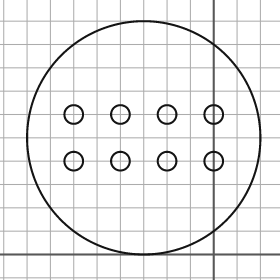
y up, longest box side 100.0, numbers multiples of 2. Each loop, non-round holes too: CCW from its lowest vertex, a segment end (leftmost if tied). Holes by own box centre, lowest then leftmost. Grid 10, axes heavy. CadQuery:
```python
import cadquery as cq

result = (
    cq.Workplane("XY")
    .moveTo(-30.0, 50.0)
    .circle(50.0)
    .moveTo(-60.0, 40.0)
    .circle(4.0)
    .moveTo(-40.0, 40.0)
    .circle(4.0)
    .moveTo(-20.0, 40.0)
    .circle(4.0)
    .moveTo(0.0, 40.0)
    .circle(4.0)
    .moveTo(-60.0, 60.0)
    .circle(4.0)
    .moveTo(-40.0, 60.0)
    .circle(4.0)
    .moveTo(-20.0, 60.0)
    .circle(4.0)
    .moveTo(0.0, 60.0)
    .circle(4.0)
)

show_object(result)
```